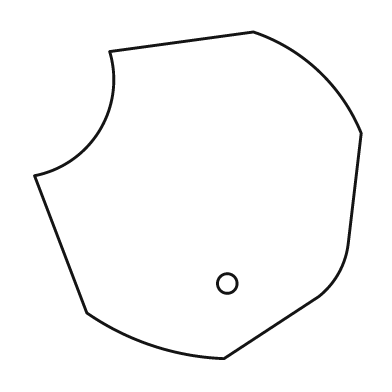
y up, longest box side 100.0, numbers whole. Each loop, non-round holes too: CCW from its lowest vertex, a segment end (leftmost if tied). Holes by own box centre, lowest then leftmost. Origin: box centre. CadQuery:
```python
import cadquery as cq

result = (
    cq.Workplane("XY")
    .moveTo(8.0, -50.0)
    .lineTo(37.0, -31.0)
    .threePointArc((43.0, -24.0), (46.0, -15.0))
    .lineTo(50.0, 19.0)
    .threePointArc((37.0, 38.0), (17.0, 50.0))
    .lineTo(-27.0, 44.0)
    .threePointArc((-30.0, 20.0), (-50.0, 6.0))
    .lineTo(-34.0, -36.0)
    .threePointArc((-14.0, -46.0), (8.0, -50.0))
    .close()
    .moveTo(9.0, -27.0)
    .circle(3.0)
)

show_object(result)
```